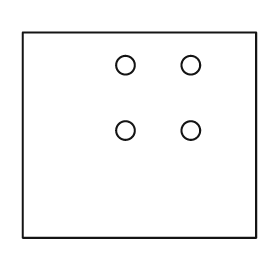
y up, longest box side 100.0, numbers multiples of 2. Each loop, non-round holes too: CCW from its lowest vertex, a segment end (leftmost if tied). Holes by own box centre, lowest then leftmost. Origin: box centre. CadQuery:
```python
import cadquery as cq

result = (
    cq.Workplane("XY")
    .moveTo(-50.0, -44.0)
    .lineTo(50.0, -44.0)
    .lineTo(50.0, 44.0)
    .lineTo(-50.0, 44.0)
    .close()
    .moveTo(-6.0, 2.0)
    .circle(4.0)
    .moveTo(22.0, 2.0)
    .circle(4.0)
    .moveTo(-6.0, 30.0)
    .circle(4.0)
    .moveTo(22.0, 30.0)
    .circle(4.0)
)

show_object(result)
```